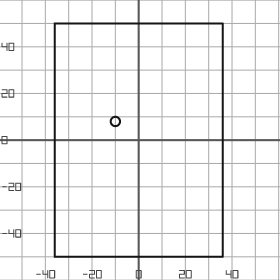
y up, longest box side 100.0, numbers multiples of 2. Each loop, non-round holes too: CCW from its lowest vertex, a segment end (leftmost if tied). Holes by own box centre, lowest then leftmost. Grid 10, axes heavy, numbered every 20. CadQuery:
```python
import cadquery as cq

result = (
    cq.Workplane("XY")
    .moveTo(-36.0, -50.0)
    .lineTo(36.0, -50.0)
    .lineTo(36.0, 50.0)
    .lineTo(-36.0, 50.0)
    .close()
    .moveTo(-10.0, 8.0)
    .circle(2.0)
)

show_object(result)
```